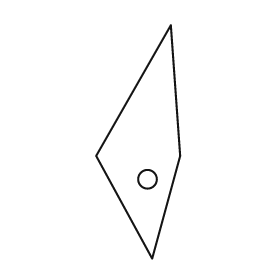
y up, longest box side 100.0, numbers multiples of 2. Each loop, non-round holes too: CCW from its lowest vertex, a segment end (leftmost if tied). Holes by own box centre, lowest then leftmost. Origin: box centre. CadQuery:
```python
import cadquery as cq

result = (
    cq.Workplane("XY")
    .moveTo(6.0, -50.0)
    .lineTo(18.0, -6.0)
    .lineTo(14.0, 50.0)
    .lineTo(-18.0, -6.0)
    .close()
    .moveTo(4.0, -16.0)
    .circle(4.0)
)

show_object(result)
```